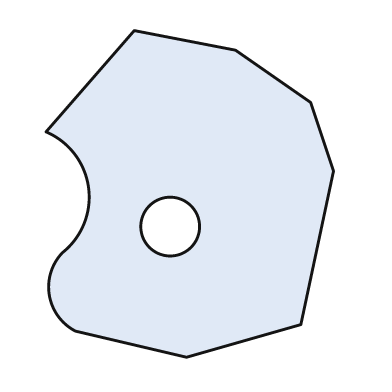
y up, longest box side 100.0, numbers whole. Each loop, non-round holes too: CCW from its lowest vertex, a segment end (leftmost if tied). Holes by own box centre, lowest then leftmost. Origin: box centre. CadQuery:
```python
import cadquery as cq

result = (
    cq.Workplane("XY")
    .moveTo(-1.0, -50.0)
    .lineTo(34.0, -40.0)
    .lineTo(44.0, 7.0)
    .lineTo(37.0, 28.0)
    .lineTo(14.0, 44.0)
    .lineTo(-17.0, 50.0)
    .lineTo(-44.0, 19.0)
    .threePointArc((-31.0, 2.0), (-39.0, -18.0))
    .threePointArc((-43.0, -31.0), (-35.0, -42.0))
    .close()
    .moveTo(-6.0, -10.0)
    .circle(9.0)
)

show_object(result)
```